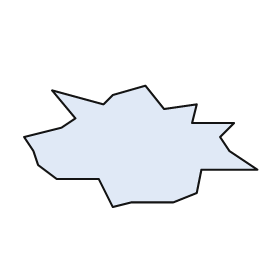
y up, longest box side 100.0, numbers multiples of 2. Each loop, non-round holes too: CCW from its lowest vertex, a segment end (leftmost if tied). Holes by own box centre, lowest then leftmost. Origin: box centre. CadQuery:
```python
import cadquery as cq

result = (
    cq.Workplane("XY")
    .moveTo(-12.0, -26.0)
    .lineTo(-4.0, -24.0)
    .lineTo(14.0, -24.0)
    .lineTo(24.0, -20.0)
    .lineTo(26.0, -10.0)
    .lineTo(50.0, -10.0)
    .lineTo(38.0, -2.0)
    .lineTo(34.0, 4.0)
    .lineTo(40.0, 10.0)
    .lineTo(22.0, 10.0)
    .lineTo(24.0, 18.0)
    .lineTo(10.0, 16.0)
    .lineTo(2.0, 26.0)
    .lineTo(-12.0, 22.0)
    .lineTo(-16.0, 18.0)
    .lineTo(-38.0, 24.0)
    .lineTo(-28.0, 12.0)
    .lineTo(-34.0, 8.0)
    .lineTo(-50.0, 4.0)
    .lineTo(-46.0, -2.0)
    .lineTo(-44.0, -8.0)
    .lineTo(-36.0, -14.0)
    .lineTo(-18.0, -14.0)
    .close()
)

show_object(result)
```